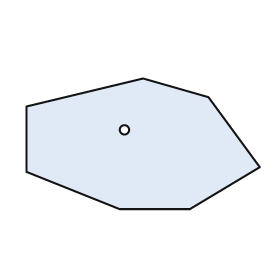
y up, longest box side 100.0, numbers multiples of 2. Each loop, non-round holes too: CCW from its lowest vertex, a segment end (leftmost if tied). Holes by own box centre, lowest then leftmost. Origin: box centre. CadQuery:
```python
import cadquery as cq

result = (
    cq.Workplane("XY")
    .moveTo(-10.0, -28.0)
    .lineTo(20.0, -28.0)
    .lineTo(50.0, -10.0)
    .lineTo(28.0, 20.0)
    .lineTo(0.0, 28.0)
    .lineTo(-50.0, 16.0)
    .lineTo(-50.0, -12.0)
    .close()
    .moveTo(-8.0, 6.0)
    .circle(2.0)
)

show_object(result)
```